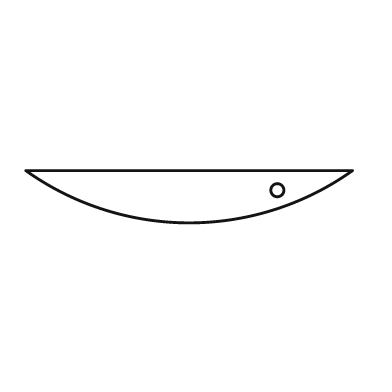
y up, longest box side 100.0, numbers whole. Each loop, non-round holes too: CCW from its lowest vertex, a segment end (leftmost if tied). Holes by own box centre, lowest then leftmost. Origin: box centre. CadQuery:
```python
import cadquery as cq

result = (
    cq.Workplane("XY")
    .moveTo(-50.0, 8.0)
    .threePointArc((0.0, -8.0), (50.0, 8.0))
    .close()
    .moveTo(27.0, 2.0)
    .circle(2.0)
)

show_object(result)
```